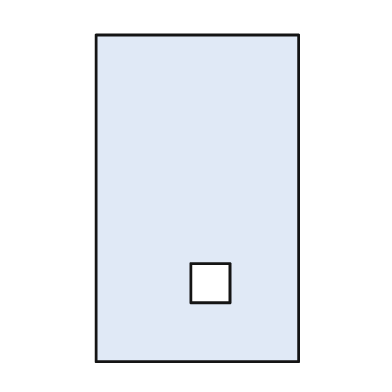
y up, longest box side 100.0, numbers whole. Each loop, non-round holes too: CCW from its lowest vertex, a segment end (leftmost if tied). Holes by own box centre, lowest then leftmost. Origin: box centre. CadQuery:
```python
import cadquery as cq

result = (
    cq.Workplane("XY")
    .moveTo(-31.0, -50.0)
    .lineTo(31.0, -50.0)
    .lineTo(31.0, 50.0)
    .lineTo(-31.0, 50.0)
    .close()
    .moveTo(-2.0, -32.0)
    .lineTo(10.0, -32.0)
    .lineTo(10.0, -20.0)
    .lineTo(-2.0, -20.0)
    .close()
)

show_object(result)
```